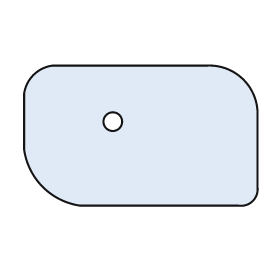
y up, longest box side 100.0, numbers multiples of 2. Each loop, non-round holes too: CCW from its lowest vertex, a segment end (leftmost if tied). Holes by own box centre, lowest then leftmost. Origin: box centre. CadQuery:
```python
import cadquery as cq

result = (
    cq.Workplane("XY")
    .moveTo(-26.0, -30.0)
    .lineTo(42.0, -30.0)
    .threePointArc((48.0, -28.0), (50.0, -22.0))
    .lineTo(50.0, 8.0)
    .threePointArc((44.0, 24.0), (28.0, 30.0))
    .lineTo(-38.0, 30.0)
    .threePointArc((-46.0, 26.0), (-50.0, 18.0))
    .lineTo(-50.0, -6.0)
    .threePointArc((-42.0, -22.0), (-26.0, -30.0))
    .close()
    .moveTo(-12.0, 6.0)
    .circle(4.0)
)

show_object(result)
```